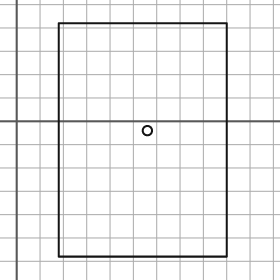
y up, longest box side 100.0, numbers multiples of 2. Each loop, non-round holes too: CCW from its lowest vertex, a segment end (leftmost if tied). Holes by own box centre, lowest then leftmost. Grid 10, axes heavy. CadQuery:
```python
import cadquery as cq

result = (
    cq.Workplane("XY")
    .moveTo(18.0, -58.0)
    .lineTo(90.0, -58.0)
    .lineTo(90.0, 42.0)
    .lineTo(18.0, 42.0)
    .close()
    .moveTo(56.0, -4.0)
    .circle(2.0)
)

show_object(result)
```